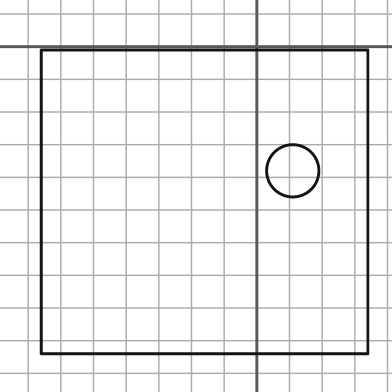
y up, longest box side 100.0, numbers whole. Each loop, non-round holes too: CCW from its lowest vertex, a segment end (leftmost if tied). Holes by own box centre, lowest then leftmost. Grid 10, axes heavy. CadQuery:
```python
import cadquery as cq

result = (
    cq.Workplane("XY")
    .moveTo(-66.0, -94.0)
    .lineTo(34.0, -94.0)
    .lineTo(34.0, -1.0)
    .lineTo(-66.0, -1.0)
    .close()
    .moveTo(11.0, -38.0)
    .circle(8.0)
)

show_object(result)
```